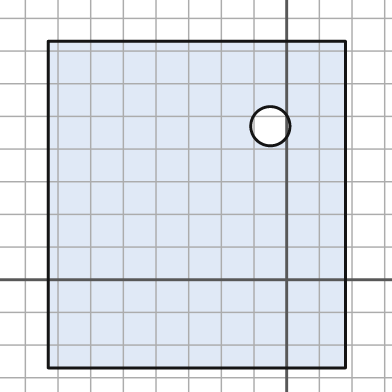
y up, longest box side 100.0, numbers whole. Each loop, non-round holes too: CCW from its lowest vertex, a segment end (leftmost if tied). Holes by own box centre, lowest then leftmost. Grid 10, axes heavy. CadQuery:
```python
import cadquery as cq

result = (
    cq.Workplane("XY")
    .moveTo(-73.0, -27.0)
    .lineTo(18.0, -27.0)
    .lineTo(18.0, 73.0)
    .lineTo(-73.0, 73.0)
    .close()
    .moveTo(-5.0, 47.0)
    .circle(6.0)
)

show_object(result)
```